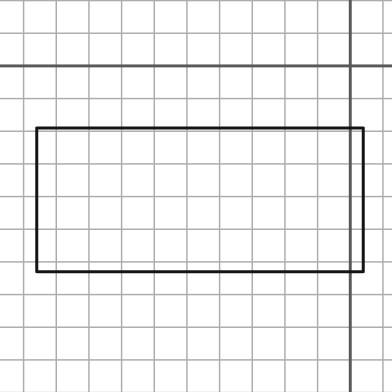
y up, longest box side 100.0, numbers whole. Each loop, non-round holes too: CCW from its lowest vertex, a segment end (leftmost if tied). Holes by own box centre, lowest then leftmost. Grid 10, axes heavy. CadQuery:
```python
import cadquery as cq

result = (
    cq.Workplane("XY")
    .moveTo(-96.0, -63.0)
    .lineTo(4.0, -63.0)
    .lineTo(4.0, -19.0)
    .lineTo(-96.0, -19.0)
    .close()
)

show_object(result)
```